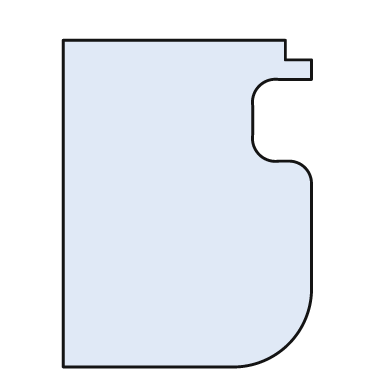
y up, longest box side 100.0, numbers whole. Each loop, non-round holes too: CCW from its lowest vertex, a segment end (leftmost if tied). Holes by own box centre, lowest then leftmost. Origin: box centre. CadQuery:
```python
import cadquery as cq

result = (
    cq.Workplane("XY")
    .moveTo(-38.0, -50.0)
    .lineTo(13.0, -50.0)
    .threePointArc((31.0, -43.0), (38.0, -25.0))
    .lineTo(38.0, 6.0)
    .threePointArc((36.0, 11.0), (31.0, 13.0))
    .lineTo(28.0, 13.0)
    .threePointArc((22.0, 15.0), (20.0, 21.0))
    .lineTo(20.0, 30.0)
    .threePointArc((22.0, 36.0), (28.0, 38.0))
    .lineTo(38.0, 38.0)
    .lineTo(38.0, 44.0)
    .lineTo(30.0, 44.0)
    .lineTo(30.0, 50.0)
    .lineTo(-38.0, 50.0)
    .close()
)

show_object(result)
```